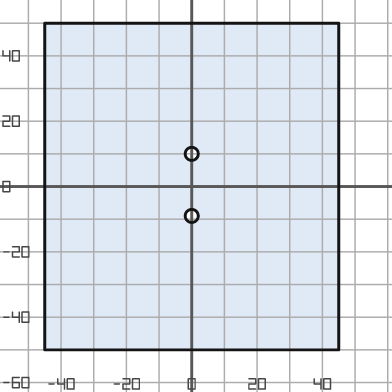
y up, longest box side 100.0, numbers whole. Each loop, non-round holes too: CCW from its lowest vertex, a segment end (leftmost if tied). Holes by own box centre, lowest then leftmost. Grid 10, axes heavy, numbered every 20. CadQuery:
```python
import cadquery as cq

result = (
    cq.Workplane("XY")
    .moveTo(-45.0, -50.0)
    .lineTo(45.0, -50.0)
    .lineTo(45.0, 50.0)
    .lineTo(-45.0, 50.0)
    .close()
    .moveTo(0.0, -9.0)
    .circle(2.0)
    .moveTo(0.0, 10.0)
    .circle(2.0)
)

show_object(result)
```